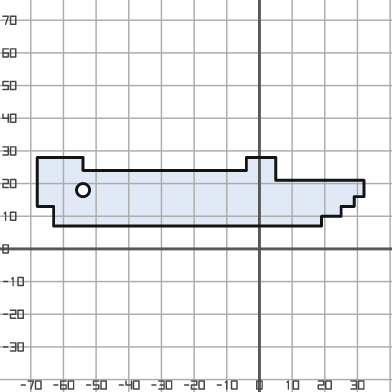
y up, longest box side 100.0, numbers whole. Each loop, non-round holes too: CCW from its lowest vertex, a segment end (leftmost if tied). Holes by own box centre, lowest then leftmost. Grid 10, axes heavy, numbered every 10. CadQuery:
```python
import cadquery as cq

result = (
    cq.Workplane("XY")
    .moveTo(-63.0, 7.0)
    .lineTo(19.0, 7.0)
    .lineTo(19.0, 10.0)
    .lineTo(25.0, 10.0)
    .lineTo(25.0, 13.0)
    .lineTo(29.0, 13.0)
    .lineTo(29.0, 16.0)
    .lineTo(32.0, 16.0)
    .lineTo(32.0, 21.0)
    .lineTo(5.0, 21.0)
    .lineTo(5.0, 28.0)
    .lineTo(-4.0, 28.0)
    .lineTo(-4.0, 24.0)
    .lineTo(-54.0, 24.0)
    .lineTo(-54.0, 28.0)
    .lineTo(-68.0, 28.0)
    .lineTo(-68.0, 13.0)
    .lineTo(-63.0, 13.0)
    .close()
    .moveTo(-54.0, 18.0)
    .circle(2.0)
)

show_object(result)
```